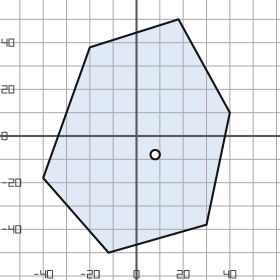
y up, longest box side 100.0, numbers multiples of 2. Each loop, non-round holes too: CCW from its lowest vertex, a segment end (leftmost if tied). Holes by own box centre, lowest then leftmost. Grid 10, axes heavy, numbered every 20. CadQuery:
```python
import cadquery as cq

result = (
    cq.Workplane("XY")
    .moveTo(-12.0, -50.0)
    .lineTo(30.0, -38.0)
    .lineTo(40.0, 10.0)
    .lineTo(18.0, 50.0)
    .lineTo(-20.0, 38.0)
    .lineTo(-40.0, -18.0)
    .close()
    .moveTo(8.0, -8.0)
    .circle(2.0)
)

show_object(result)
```